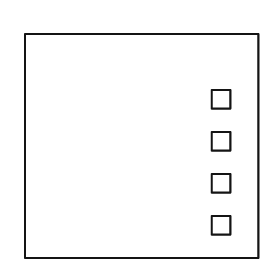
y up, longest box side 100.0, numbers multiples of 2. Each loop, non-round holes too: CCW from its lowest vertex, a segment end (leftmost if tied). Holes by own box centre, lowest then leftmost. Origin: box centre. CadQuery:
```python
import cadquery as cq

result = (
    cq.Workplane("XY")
    .moveTo(-50.0, -48.0)
    .lineTo(50.0, -48.0)
    .lineTo(50.0, 48.0)
    .lineTo(-50.0, 48.0)
    .close()
    .moveTo(30.0, -38.0)
    .lineTo(38.0, -38.0)
    .lineTo(38.0, -30.0)
    .lineTo(30.0, -30.0)
    .close()
    .moveTo(30.0, -20.0)
    .lineTo(38.0, -20.0)
    .lineTo(38.0, -12.0)
    .lineTo(30.0, -12.0)
    .close()
    .moveTo(30.0, -2.0)
    .lineTo(38.0, -2.0)
    .lineTo(38.0, 6.0)
    .lineTo(30.0, 6.0)
    .close()
    .moveTo(30.0, 16.0)
    .lineTo(38.0, 16.0)
    .lineTo(38.0, 24.0)
    .lineTo(30.0, 24.0)
    .close()
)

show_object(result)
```